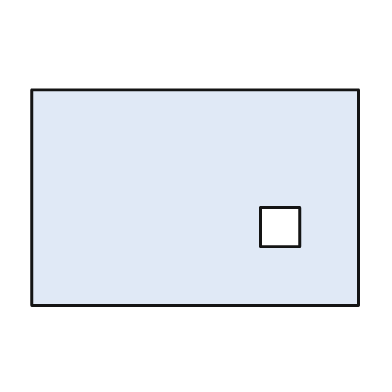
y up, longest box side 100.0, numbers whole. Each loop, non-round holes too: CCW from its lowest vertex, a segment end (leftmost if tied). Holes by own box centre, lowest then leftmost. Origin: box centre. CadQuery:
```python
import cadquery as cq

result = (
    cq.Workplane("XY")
    .moveTo(-50.0, -33.0)
    .lineTo(50.0, -33.0)
    .lineTo(50.0, 33.0)
    .lineTo(-50.0, 33.0)
    .close()
    .moveTo(20.0, -15.0)
    .lineTo(32.0, -15.0)
    .lineTo(32.0, -3.0)
    .lineTo(20.0, -3.0)
    .close()
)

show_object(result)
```